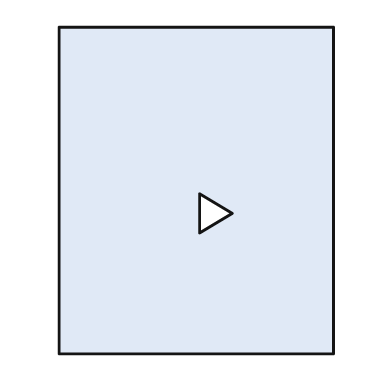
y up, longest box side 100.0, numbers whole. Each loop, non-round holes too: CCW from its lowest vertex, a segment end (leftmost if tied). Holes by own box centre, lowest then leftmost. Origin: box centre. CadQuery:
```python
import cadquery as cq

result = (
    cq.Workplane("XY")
    .moveTo(-42.0, -50.0)
    .lineTo(42.0, -50.0)
    .lineTo(42.0, 50.0)
    .lineTo(-42.0, 50.0)
    .close()
    .moveTo(1.0, -13.0)
    .lineTo(11.0, -7.0)
    .lineTo(1.0, -1.0)
    .close()
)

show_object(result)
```